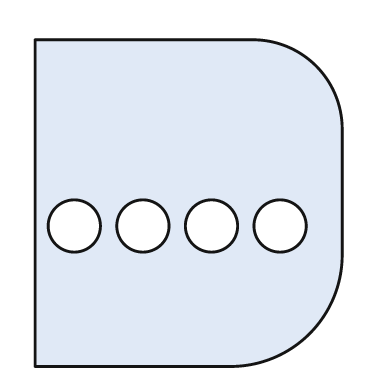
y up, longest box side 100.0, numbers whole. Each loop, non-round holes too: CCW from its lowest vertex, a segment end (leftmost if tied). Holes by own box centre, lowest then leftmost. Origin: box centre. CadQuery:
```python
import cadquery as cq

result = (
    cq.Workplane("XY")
    .moveTo(-47.0, -50.0)
    .lineTo(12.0, -50.0)
    .threePointArc((37.0, -40.0), (47.0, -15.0))
    .lineTo(47.0, 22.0)
    .threePointArc((39.0, 42.0), (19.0, 50.0))
    .lineTo(-47.0, 50.0)
    .close()
    .moveTo(-35.0, -7.0)
    .circle(8.0)
    .moveTo(-14.0, -7.0)
    .circle(8.0)
    .moveTo(7.0, -7.0)
    .circle(8.0)
    .moveTo(28.0, -7.0)
    .circle(8.0)
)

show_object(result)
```